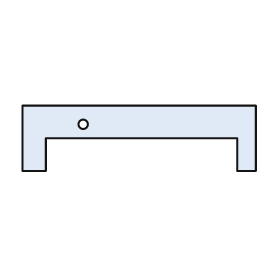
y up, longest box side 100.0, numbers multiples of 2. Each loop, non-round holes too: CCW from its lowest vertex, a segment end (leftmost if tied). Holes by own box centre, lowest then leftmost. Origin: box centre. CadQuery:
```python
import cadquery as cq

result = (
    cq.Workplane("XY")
    .moveTo(-50.0, -14.0)
    .lineTo(-40.0, -14.0)
    .lineTo(-40.0, 0.0)
    .lineTo(42.0, 0.0)
    .lineTo(42.0, -14.0)
    .lineTo(50.0, -14.0)
    .lineTo(50.0, 14.0)
    .lineTo(-50.0, 14.0)
    .close()
    .moveTo(-24.0, 6.0)
    .circle(2.0)
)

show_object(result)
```